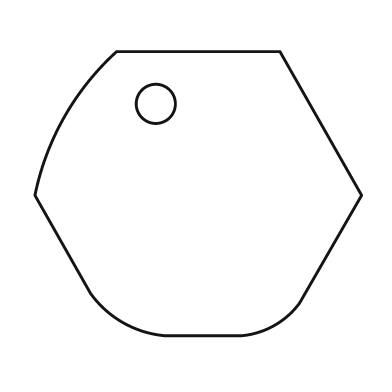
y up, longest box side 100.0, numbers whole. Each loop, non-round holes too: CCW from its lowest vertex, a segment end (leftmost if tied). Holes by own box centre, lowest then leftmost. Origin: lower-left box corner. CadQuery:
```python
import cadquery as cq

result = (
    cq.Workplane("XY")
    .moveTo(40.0, 0.0)
    .lineTo(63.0, 0.0)
    .threePointArc((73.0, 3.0), (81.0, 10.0))
    .lineTo(100.0, 43.0)
    .lineTo(75.0, 87.0)
    .lineTo(25.0, 87.0)
    .threePointArc((9.0, 67.0), (0.0, 43.0))
    .lineTo(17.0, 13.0)
    .threePointArc((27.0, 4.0), (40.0, 0.0))
    .close()
    .moveTo(37.0, 71.0)
    .circle(6.0)
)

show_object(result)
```